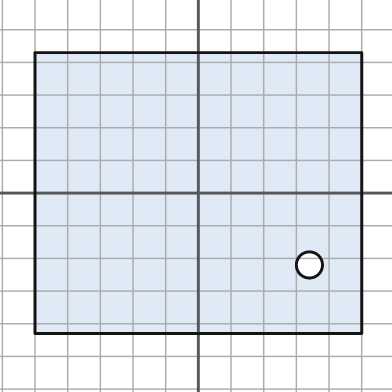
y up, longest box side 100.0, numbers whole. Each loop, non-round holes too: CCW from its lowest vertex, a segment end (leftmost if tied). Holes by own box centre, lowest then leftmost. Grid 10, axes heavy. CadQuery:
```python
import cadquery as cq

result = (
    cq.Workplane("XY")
    .moveTo(-50.0, -43.0)
    .lineTo(50.0, -43.0)
    .lineTo(50.0, 43.0)
    .lineTo(-50.0, 43.0)
    .close()
    .moveTo(34.0, -22.0)
    .circle(4.0)
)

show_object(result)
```